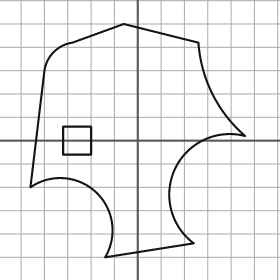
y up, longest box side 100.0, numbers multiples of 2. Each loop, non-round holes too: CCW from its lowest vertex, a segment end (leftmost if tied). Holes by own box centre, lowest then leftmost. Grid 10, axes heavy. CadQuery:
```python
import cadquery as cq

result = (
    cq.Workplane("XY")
    .moveTo(-14.0, -50.0)
    .lineTo(24.0, -44.0)
    .threePointArc((16.0, -12.0), (46.0, 2.0))
    .threePointArc((32.0, 20.0), (26.0, 42.0))
    .lineTo(-6.0, 50.0)
    .lineTo(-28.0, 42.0)
    .threePointArc((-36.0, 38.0), (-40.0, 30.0))
    .lineTo(-46.0, -20.0)
    .threePointArc((-18.0, -22.0), (-14.0, -50.0))
    .close()
    .moveTo(-32.0, -6.0)
    .lineTo(-20.0, -6.0)
    .lineTo(-20.0, 6.0)
    .lineTo(-32.0, 6.0)
    .close()
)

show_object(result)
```